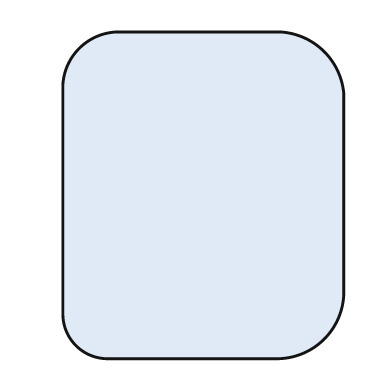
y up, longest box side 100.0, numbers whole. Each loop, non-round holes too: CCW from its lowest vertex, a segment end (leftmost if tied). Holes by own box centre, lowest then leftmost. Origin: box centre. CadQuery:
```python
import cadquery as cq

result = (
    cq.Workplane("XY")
    .moveTo(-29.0, -50.0)
    .lineTo(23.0, -50.0)
    .threePointArc((37.0, -44.0), (43.0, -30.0))
    .lineTo(43.0, 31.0)
    .threePointArc((37.0, 44.0), (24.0, 50.0))
    .lineTo(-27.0, 50.0)
    .threePointArc((-38.0, 45.0), (-43.0, 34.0))
    .lineTo(-43.0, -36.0)
    .threePointArc((-39.0, -46.0), (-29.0, -50.0))
    .close()
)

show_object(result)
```